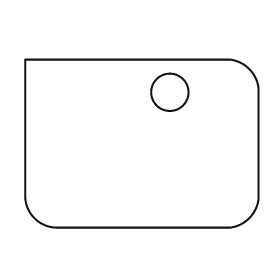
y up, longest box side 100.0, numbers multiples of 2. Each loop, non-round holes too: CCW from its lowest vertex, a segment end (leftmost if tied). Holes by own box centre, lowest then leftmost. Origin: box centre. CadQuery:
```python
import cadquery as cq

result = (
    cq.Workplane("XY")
    .moveTo(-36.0, -36.0)
    .lineTo(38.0, -36.0)
    .threePointArc((46.0, -32.0), (50.0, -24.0))
    .lineTo(50.0, 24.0)
    .threePointArc((46.0, 32.0), (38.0, 36.0))
    .lineTo(-50.0, 36.0)
    .lineTo(-50.0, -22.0)
    .threePointArc((-46.0, -32.0), (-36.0, -36.0))
    .close()
    .moveTo(12.0, 22.0)
    .circle(8.0)
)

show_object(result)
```